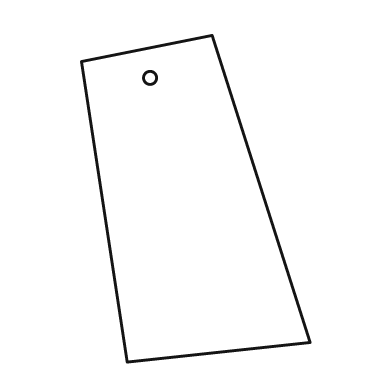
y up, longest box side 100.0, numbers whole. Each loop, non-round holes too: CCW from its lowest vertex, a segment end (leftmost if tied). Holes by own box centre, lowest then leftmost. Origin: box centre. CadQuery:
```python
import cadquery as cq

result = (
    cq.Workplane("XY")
    .moveTo(-21.0, -50.0)
    .lineTo(35.0, -44.0)
    .lineTo(5.0, 50.0)
    .lineTo(-35.0, 42.0)
    .close()
    .moveTo(-14.0, 37.0)
    .circle(2.0)
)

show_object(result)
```